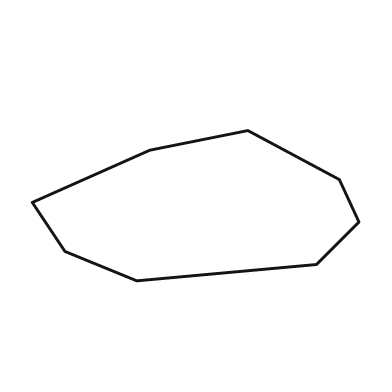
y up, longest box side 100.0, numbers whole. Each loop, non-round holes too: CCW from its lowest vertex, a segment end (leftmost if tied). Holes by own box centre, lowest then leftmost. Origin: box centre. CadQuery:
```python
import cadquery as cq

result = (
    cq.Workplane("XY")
    .moveTo(-18.0, -23.0)
    .lineTo(37.0, -18.0)
    .lineTo(50.0, -5.0)
    .lineTo(44.0, 8.0)
    .lineTo(16.0, 23.0)
    .lineTo(-14.0, 17.0)
    .lineTo(-50.0, 1.0)
    .lineTo(-40.0, -14.0)
    .close()
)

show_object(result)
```